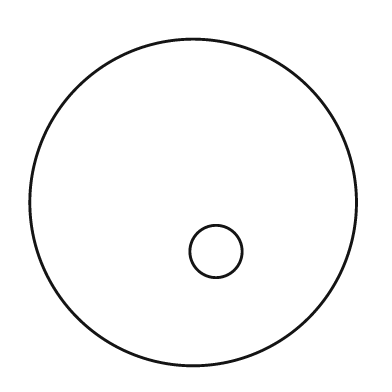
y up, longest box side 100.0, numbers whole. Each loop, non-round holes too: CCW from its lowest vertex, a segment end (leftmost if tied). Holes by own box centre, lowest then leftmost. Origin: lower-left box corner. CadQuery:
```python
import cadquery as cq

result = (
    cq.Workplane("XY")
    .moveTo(50.0, 50.0)
    .circle(50.0)
    .moveTo(57.0, 35.0)
    .circle(8.0)
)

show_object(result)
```